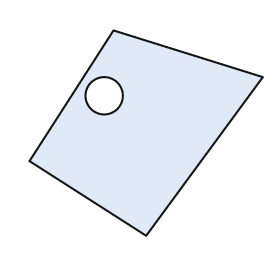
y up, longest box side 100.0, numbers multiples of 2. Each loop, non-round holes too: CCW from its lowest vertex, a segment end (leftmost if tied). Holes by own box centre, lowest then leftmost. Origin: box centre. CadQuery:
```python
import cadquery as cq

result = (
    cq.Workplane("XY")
    .moveTo(0.0, -44.0)
    .lineTo(50.0, 24.0)
    .lineTo(-14.0, 44.0)
    .lineTo(-50.0, -12.0)
    .close()
    .moveTo(-18.0, 16.0)
    .circle(8.0)
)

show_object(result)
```